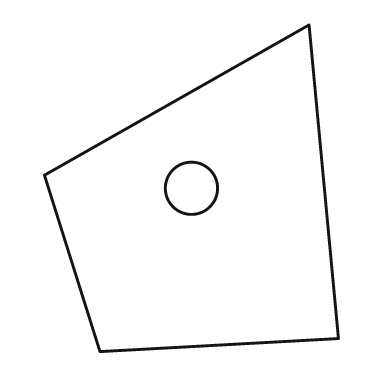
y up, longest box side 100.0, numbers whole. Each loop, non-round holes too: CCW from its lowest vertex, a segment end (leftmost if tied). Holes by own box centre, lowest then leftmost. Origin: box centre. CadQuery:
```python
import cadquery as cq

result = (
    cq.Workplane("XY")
    .moveTo(-28.0, -50.0)
    .lineTo(45.0, -46.0)
    .lineTo(36.0, 50.0)
    .lineTo(-45.0, 4.0)
    .close()
    .moveTo(0.0, 0.0)
    .circle(8.0)
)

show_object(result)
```